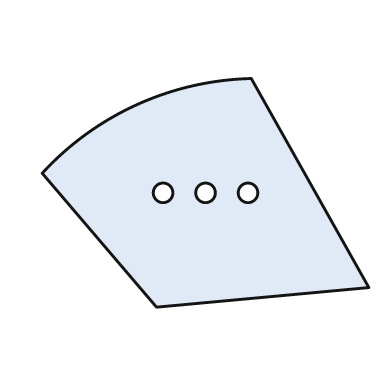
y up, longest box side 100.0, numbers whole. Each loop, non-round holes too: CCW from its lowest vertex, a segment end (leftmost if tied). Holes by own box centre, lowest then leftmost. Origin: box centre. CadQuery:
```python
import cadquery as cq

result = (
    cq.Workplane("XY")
    .moveTo(-15.0, -35.0)
    .lineTo(50.0, -29.0)
    .lineTo(14.0, 35.0)
    .threePointArc((-21.0, 27.0), (-50.0, 6.0))
    .close()
    .moveTo(-13.0, 0.0)
    .circle(3.0)
    .moveTo(0.0, 0.0)
    .circle(3.0)
    .moveTo(13.0, 0.0)
    .circle(3.0)
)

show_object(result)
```